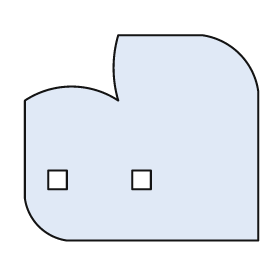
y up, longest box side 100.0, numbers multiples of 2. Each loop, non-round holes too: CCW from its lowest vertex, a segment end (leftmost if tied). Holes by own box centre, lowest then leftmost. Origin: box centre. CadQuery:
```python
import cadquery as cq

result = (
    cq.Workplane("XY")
    .moveTo(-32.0, -44.0)
    .lineTo(50.0, -44.0)
    .lineTo(50.0, 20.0)
    .threePointArc((42.0, 36.0), (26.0, 44.0))
    .lineTo(-10.0, 44.0)
    .threePointArc((-12.0, 30.0), (-10.0, 16.0))
    .threePointArc((-30.0, 22.0), (-50.0, 16.0))
    .lineTo(-50.0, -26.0)
    .threePointArc((-44.0, -38.0), (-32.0, -44.0))
    .close()
    .moveTo(-40.0, -22.0)
    .lineTo(-32.0, -22.0)
    .lineTo(-32.0, -14.0)
    .lineTo(-40.0, -14.0)
    .close()
    .moveTo(-4.0, -22.0)
    .lineTo(4.0, -22.0)
    .lineTo(4.0, -14.0)
    .lineTo(-4.0, -14.0)
    .close()
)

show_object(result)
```